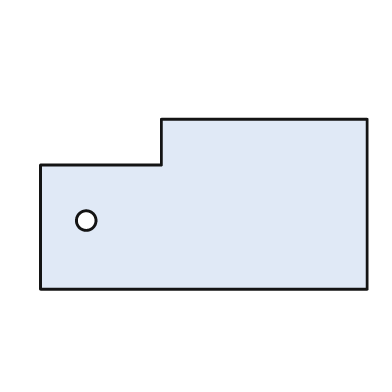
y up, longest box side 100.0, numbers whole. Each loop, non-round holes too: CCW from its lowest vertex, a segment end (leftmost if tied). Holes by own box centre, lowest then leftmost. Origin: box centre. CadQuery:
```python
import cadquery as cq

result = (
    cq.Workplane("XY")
    .moveTo(-50.0, -26.0)
    .lineTo(50.0, -26.0)
    .lineTo(50.0, 26.0)
    .lineTo(-13.0, 26.0)
    .lineTo(-13.0, 12.0)
    .lineTo(-50.0, 12.0)
    .close()
    .moveTo(-36.0, -5.0)
    .circle(3.0)
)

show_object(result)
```